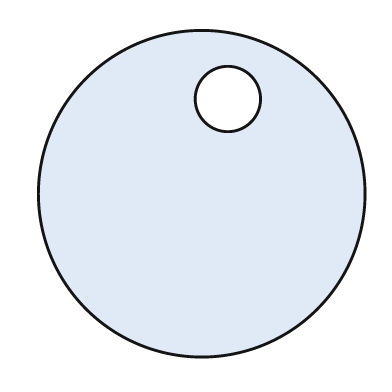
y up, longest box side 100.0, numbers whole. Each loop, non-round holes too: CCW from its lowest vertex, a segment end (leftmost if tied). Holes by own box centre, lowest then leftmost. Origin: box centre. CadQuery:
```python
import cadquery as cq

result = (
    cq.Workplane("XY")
    .moveTo(0.0, 0.0)
    .circle(50.0)
    .moveTo(8.0, 29.0)
    .circle(10.0)
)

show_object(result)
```